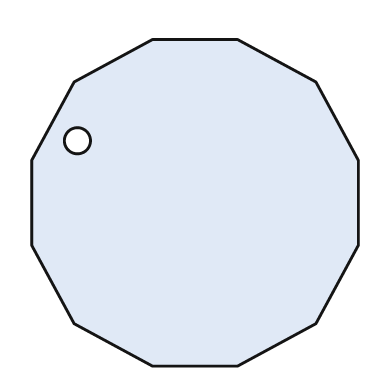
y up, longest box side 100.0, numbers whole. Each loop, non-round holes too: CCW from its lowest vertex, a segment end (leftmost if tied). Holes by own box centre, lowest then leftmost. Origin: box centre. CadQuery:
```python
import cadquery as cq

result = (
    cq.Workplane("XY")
    .moveTo(-13.0, -50.0)
    .lineTo(13.0, -50.0)
    .lineTo(37.0, -37.0)
    .lineTo(50.0, -13.0)
    .lineTo(50.0, 13.0)
    .lineTo(37.0, 37.0)
    .lineTo(13.0, 50.0)
    .lineTo(-13.0, 50.0)
    .lineTo(-37.0, 37.0)
    .lineTo(-50.0, 13.0)
    .lineTo(-50.0, -13.0)
    .lineTo(-37.0, -37.0)
    .close()
    .moveTo(-36.0, 19.0)
    .circle(4.0)
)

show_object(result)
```